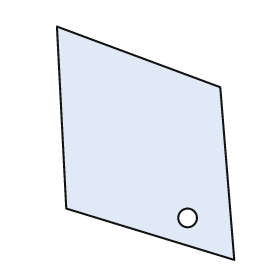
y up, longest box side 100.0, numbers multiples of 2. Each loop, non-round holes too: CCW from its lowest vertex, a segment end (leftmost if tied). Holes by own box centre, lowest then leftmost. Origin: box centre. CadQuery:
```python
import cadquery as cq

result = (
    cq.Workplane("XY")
    .moveTo(38.0, -50.0)
    .lineTo(32.0, 24.0)
    .lineTo(-38.0, 50.0)
    .lineTo(-34.0, -28.0)
    .close()
    .moveTo(18.0, -32.0)
    .circle(4.0)
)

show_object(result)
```